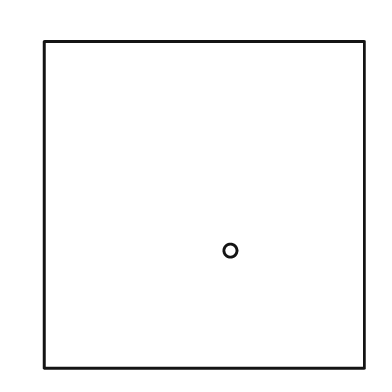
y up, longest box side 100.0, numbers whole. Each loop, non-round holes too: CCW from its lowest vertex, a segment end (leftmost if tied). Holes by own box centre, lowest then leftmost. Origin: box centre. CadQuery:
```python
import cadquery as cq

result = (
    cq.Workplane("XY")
    .moveTo(-49.0, -50.0)
    .lineTo(49.0, -50.0)
    .lineTo(49.0, 50.0)
    .lineTo(-49.0, 50.0)
    .close()
    .moveTo(8.0, -14.0)
    .circle(2.0)
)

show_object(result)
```